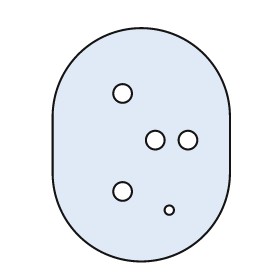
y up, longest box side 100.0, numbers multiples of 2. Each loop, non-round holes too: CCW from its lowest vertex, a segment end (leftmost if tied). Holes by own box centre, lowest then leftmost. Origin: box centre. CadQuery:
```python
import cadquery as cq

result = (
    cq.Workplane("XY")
    .moveTo(-38.0, -12.0)
    .threePointArc((0.0, -50.0), (38.0, -12.0))
    .lineTo(38.0, 12.0)
    .threePointArc((0.0, 50.0), (-38.0, 12.0))
    .close()
    .moveTo(12.0, -28.0)
    .circle(2.0)
    .moveTo(-8.0, -20.0)
    .circle(4.0)
    .moveTo(6.0, 2.0)
    .circle(4.0)
    .moveTo(20.0, 2.0)
    .circle(4.0)
    .moveTo(-8.0, 22.0)
    .circle(4.0)
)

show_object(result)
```